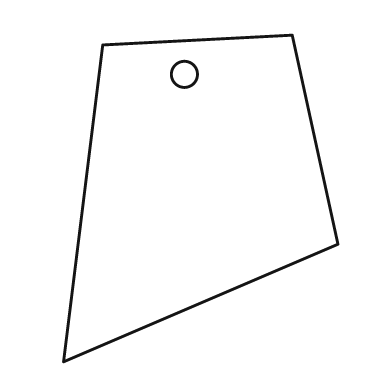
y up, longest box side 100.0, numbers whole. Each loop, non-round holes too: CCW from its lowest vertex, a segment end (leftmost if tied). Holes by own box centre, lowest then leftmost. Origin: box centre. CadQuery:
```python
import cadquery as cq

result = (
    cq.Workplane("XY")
    .moveTo(-42.0, -50.0)
    .lineTo(42.0, -14.0)
    .lineTo(28.0, 50.0)
    .lineTo(-30.0, 47.0)
    .close()
    .moveTo(-5.0, 38.0)
    .circle(4.0)
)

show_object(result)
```